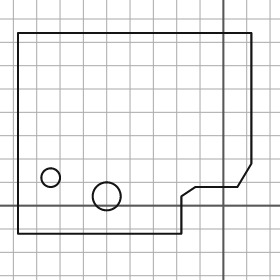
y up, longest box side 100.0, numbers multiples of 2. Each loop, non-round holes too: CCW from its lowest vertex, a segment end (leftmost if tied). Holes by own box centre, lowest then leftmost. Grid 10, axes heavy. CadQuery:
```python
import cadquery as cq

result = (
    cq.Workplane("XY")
    .moveTo(-88.0, -12.0)
    .lineTo(-18.0, -12.0)
    .lineTo(-18.0, 4.0)
    .lineTo(-12.0, 8.0)
    .lineTo(6.0, 8.0)
    .lineTo(12.0, 18.0)
    .lineTo(12.0, 74.0)
    .lineTo(-88.0, 74.0)
    .close()
    .moveTo(-50.0, 4.0)
    .circle(6.0)
    .moveTo(-74.0, 12.0)
    .circle(4.0)
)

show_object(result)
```